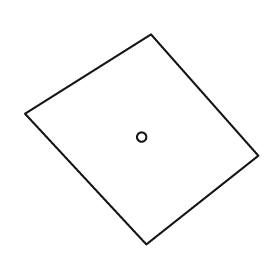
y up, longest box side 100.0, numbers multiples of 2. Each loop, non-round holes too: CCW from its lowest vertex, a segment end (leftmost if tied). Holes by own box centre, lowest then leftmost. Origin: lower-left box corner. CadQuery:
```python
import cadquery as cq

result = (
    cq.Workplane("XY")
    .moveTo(52.0, 0.0)
    .lineTo(100.0, 38.0)
    .lineTo(54.0, 90.0)
    .lineTo(0.0, 56.0)
    .close()
    .moveTo(50.0, 46.0)
    .circle(2.0)
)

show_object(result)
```